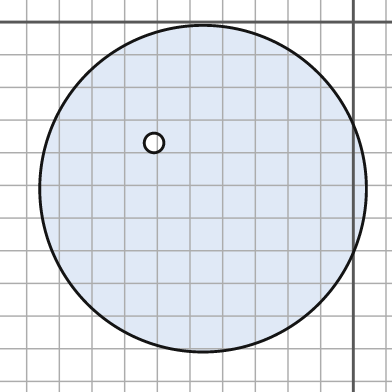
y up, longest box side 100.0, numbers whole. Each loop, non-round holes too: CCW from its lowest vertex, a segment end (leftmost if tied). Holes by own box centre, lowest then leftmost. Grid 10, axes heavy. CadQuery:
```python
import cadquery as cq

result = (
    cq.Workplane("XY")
    .moveTo(-46.0, -51.0)
    .circle(50.0)
    .moveTo(-61.0, -37.0)
    .circle(3.0)
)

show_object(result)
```